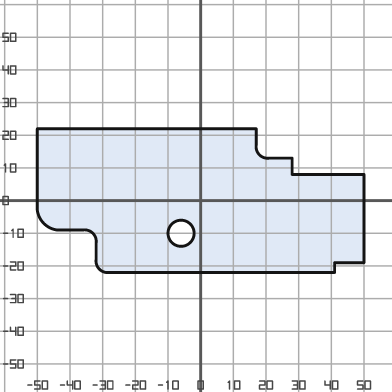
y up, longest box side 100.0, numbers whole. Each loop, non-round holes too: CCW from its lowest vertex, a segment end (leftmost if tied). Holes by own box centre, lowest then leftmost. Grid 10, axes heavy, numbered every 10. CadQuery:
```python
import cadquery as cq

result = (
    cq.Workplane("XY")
    .moveTo(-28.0, -22.0)
    .lineTo(41.0, -22.0)
    .lineTo(41.0, -19.0)
    .lineTo(50.0, -19.0)
    .lineTo(50.0, 8.0)
    .lineTo(28.0, 8.0)
    .lineTo(28.0, 13.0)
    .lineTo(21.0, 13.0)
    .threePointArc((18.0, 14.0), (17.0, 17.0))
    .lineTo(17.0, 22.0)
    .lineTo(-50.0, 22.0)
    .lineTo(-50.0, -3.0)
    .threePointArc((-48.0, -7.0), (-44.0, -9.0))
    .lineTo(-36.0, -9.0)
    .threePointArc((-33.0, -10.0), (-32.0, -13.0))
    .lineTo(-32.0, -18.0)
    .threePointArc((-31.0, -21.0), (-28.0, -22.0))
    .close()
    .moveTo(-6.0, -10.0)
    .circle(4.0)
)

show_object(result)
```